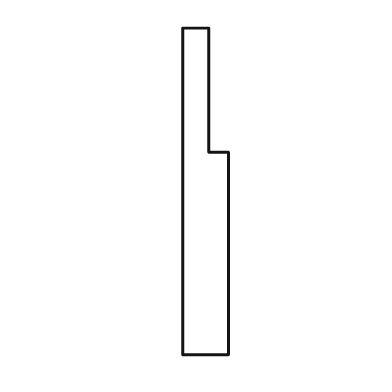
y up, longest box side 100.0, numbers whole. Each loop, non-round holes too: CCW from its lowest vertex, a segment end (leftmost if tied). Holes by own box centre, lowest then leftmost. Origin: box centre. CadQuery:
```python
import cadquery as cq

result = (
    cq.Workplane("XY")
    .moveTo(-7.0, -50.0)
    .lineTo(7.0, -50.0)
    .lineTo(7.0, 12.0)
    .lineTo(1.0, 12.0)
    .lineTo(1.0, 50.0)
    .lineTo(-7.0, 50.0)
    .close()
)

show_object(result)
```